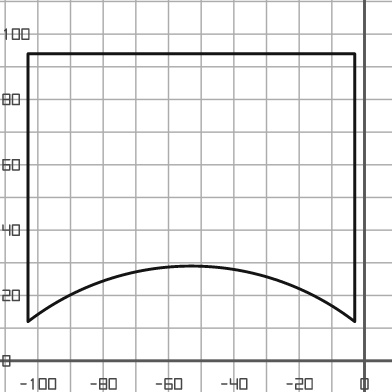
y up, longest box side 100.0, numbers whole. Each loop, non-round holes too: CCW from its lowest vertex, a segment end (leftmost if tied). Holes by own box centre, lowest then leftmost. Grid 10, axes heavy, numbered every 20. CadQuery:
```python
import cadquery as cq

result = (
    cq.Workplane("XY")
    .moveTo(-103.0, 12.0)
    .threePointArc((-53.0, 29.0), (-3.0, 12.0))
    .lineTo(-3.0, 94.0)
    .lineTo(-103.0, 94.0)
    .close()
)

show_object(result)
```